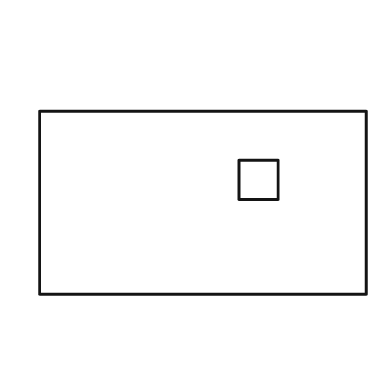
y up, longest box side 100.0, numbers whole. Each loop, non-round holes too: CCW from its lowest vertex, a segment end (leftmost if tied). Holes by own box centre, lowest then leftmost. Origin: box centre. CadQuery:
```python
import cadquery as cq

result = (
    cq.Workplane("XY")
    .moveTo(-50.0, -28.0)
    .lineTo(50.0, -28.0)
    .lineTo(50.0, 28.0)
    .lineTo(-50.0, 28.0)
    .close()
    .moveTo(11.0, 1.0)
    .lineTo(23.0, 1.0)
    .lineTo(23.0, 13.0)
    .lineTo(11.0, 13.0)
    .close()
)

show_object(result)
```